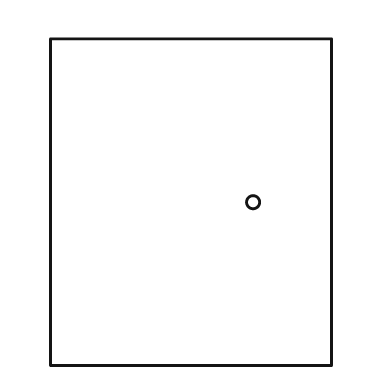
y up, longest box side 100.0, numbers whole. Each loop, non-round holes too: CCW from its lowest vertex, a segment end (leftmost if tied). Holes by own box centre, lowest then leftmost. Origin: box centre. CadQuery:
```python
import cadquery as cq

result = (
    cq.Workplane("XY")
    .moveTo(-43.0, -50.0)
    .lineTo(43.0, -50.0)
    .lineTo(43.0, 50.0)
    .lineTo(-43.0, 50.0)
    .close()
    .moveTo(19.0, 0.0)
    .circle(2.0)
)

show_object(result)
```